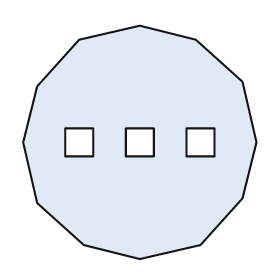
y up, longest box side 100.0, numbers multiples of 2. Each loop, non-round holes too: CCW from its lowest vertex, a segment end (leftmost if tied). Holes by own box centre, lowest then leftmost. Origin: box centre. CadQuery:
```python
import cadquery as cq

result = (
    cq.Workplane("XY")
    .moveTo(0.0, -50.0)
    .lineTo(26.0, -44.0)
    .lineTo(44.0, -24.0)
    .lineTo(50.0, 0.0)
    .lineTo(44.0, 26.0)
    .lineTo(24.0, 44.0)
    .lineTo(0.0, 50.0)
    .lineTo(-26.0, 44.0)
    .lineTo(-44.0, 24.0)
    .lineTo(-50.0, 0.0)
    .lineTo(-44.0, -26.0)
    .lineTo(-24.0, -44.0)
    .close()
    .moveTo(-32.0, -6.0)
    .lineTo(-20.0, -6.0)
    .lineTo(-20.0, 6.0)
    .lineTo(-32.0, 6.0)
    .close()
    .moveTo(-6.0, -6.0)
    .lineTo(6.0, -6.0)
    .lineTo(6.0, 6.0)
    .lineTo(-6.0, 6.0)
    .close()
    .moveTo(20.0, -6.0)
    .lineTo(32.0, -6.0)
    .lineTo(32.0, 6.0)
    .lineTo(20.0, 6.0)
    .close()
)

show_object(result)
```